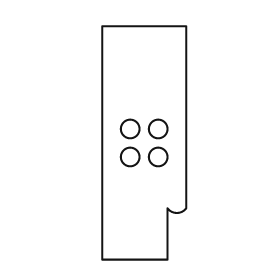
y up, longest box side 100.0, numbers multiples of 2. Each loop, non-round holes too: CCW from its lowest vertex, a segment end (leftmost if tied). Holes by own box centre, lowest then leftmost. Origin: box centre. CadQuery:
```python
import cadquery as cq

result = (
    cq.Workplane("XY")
    .moveTo(-18.0, -50.0)
    .lineTo(10.0, -50.0)
    .lineTo(10.0, -28.0)
    .threePointArc((14.0, -30.0), (18.0, -28.0))
    .lineTo(18.0, 50.0)
    .lineTo(-18.0, 50.0)
    .close()
    .moveTo(-6.0, -6.0)
    .circle(4.0)
    .moveTo(6.0, -6.0)
    .circle(4.0)
    .moveTo(-6.0, 6.0)
    .circle(4.0)
    .moveTo(6.0, 6.0)
    .circle(4.0)
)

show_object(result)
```